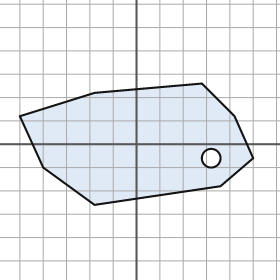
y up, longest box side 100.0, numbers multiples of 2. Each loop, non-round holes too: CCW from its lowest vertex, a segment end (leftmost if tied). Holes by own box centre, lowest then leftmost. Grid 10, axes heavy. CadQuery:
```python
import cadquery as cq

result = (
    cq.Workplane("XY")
    .moveTo(-18.0, -26.0)
    .lineTo(36.0, -18.0)
    .lineTo(50.0, -6.0)
    .lineTo(42.0, 12.0)
    .lineTo(28.0, 26.0)
    .lineTo(-18.0, 22.0)
    .lineTo(-50.0, 12.0)
    .lineTo(-40.0, -10.0)
    .close()
    .moveTo(32.0, -6.0)
    .circle(4.0)
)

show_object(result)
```